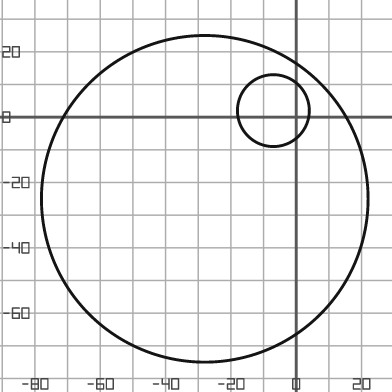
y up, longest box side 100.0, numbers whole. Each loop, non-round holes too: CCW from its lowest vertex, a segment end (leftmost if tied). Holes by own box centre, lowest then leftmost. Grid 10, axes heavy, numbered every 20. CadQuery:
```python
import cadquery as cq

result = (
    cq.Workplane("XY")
    .moveTo(-28.0, -25.0)
    .circle(50.0)
    .moveTo(-7.0, 2.0)
    .circle(11.0)
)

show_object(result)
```